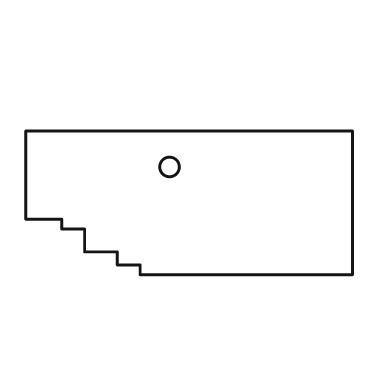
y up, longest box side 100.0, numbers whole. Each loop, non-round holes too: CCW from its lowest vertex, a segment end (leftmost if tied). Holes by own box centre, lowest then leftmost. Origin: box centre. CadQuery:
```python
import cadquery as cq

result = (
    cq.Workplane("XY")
    .moveTo(-15.0, -22.0)
    .lineTo(50.0, -22.0)
    .lineTo(50.0, 22.0)
    .lineTo(-50.0, 22.0)
    .lineTo(-50.0, -5.0)
    .lineTo(-39.0, -5.0)
    .lineTo(-39.0, -8.0)
    .lineTo(-32.0, -8.0)
    .lineTo(-32.0, -15.0)
    .lineTo(-22.0, -15.0)
    .lineTo(-22.0, -19.0)
    .lineTo(-15.0, -19.0)
    .close()
    .moveTo(-6.0, 11.0)
    .circle(3.0)
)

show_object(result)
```